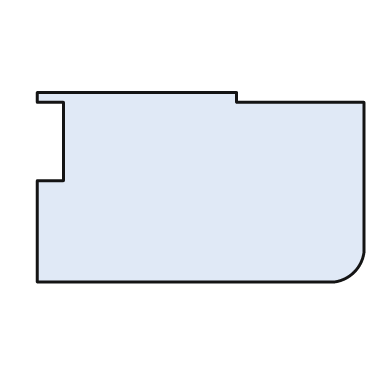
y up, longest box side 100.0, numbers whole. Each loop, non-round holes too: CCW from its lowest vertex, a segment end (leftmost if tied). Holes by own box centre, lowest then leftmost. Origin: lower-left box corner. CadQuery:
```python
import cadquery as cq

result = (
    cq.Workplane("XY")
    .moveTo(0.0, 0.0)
    .lineTo(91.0, 0.0)
    .threePointArc((97.0, 3.0), (100.0, 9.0))
    .lineTo(100.0, 55.0)
    .lineTo(61.0, 55.0)
    .lineTo(61.0, 58.0)
    .lineTo(0.0, 58.0)
    .lineTo(0.0, 55.0)
    .lineTo(8.0, 55.0)
    .lineTo(8.0, 31.0)
    .lineTo(0.0, 31.0)
    .close()
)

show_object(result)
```